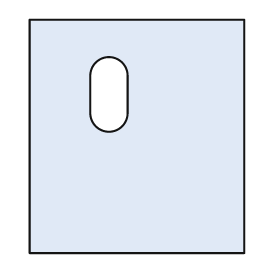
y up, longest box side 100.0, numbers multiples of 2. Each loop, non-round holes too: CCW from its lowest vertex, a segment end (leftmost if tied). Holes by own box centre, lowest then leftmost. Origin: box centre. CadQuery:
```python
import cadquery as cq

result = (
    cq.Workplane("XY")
    .moveTo(-46.0, -50.0)
    .lineTo(46.0, -50.0)
    .lineTo(46.0, 50.0)
    .lineTo(-46.0, 50.0)
    .close()
    .moveTo(-20.0, 10.0)
    .threePointArc((-12.0, 2.0), (-4.0, 10.0))
    .lineTo(-4.0, 26.0)
    .threePointArc((-12.0, 34.0), (-20.0, 26.0))
    .close()
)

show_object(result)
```